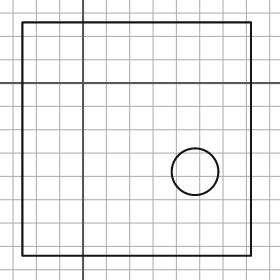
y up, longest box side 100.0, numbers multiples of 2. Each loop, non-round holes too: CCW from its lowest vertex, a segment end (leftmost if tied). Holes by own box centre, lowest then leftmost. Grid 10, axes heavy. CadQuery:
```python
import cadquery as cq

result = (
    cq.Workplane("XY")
    .moveTo(-26.0, -74.0)
    .lineTo(72.0, -74.0)
    .lineTo(72.0, 26.0)
    .lineTo(-26.0, 26.0)
    .close()
    .moveTo(48.0, -38.0)
    .circle(10.0)
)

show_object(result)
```